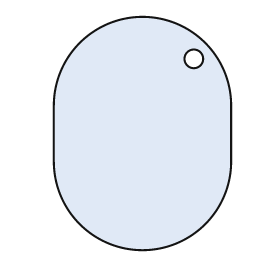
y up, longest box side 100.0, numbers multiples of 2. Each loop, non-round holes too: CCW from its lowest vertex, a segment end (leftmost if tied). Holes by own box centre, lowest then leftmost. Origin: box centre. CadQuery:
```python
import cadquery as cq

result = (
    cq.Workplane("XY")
    .moveTo(-38.0, -12.0)
    .threePointArc((0.0, -50.0), (38.0, -12.0))
    .lineTo(38.0, 12.0)
    .threePointArc((0.0, 50.0), (-38.0, 12.0))
    .close()
    .moveTo(22.0, 32.0)
    .circle(4.0)
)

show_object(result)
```